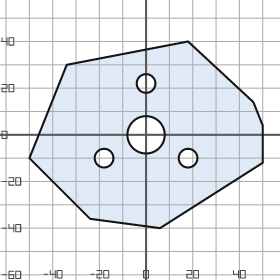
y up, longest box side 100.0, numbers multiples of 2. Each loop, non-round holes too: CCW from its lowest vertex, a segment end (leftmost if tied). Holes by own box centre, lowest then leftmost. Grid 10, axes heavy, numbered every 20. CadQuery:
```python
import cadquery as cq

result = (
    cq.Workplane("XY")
    .moveTo(6.0, -40.0)
    .lineTo(50.0, -12.0)
    .lineTo(50.0, 4.0)
    .lineTo(46.0, 14.0)
    .lineTo(18.0, 40.0)
    .lineTo(-34.0, 30.0)
    .lineTo(-50.0, -10.0)
    .lineTo(-24.0, -36.0)
    .close()
    .moveTo(-18.0, -10.0)
    .circle(4.0)
    .moveTo(18.0, -10.0)
    .circle(4.0)
    .moveTo(0.0, 0.0)
    .circle(8.0)
    .moveTo(0.0, 22.0)
    .circle(4.0)
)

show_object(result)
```